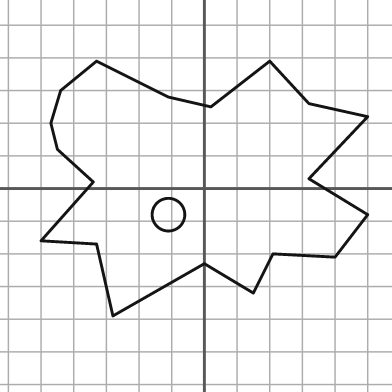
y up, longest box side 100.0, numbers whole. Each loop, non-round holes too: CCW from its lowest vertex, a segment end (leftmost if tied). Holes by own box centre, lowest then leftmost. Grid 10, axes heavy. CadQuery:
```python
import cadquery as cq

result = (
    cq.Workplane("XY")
    .moveTo(-28.0, -39.0)
    .lineTo(0.0, -23.0)
    .lineTo(15.0, -32.0)
    .lineTo(21.0, -20.0)
    .lineTo(40.0, -21.0)
    .lineTo(50.0, -8.0)
    .lineTo(32.0, 3.0)
    .lineTo(50.0, 22.0)
    .lineTo(32.0, 26.0)
    .lineTo(20.0, 39.0)
    .lineTo(2.0, 25.0)
    .lineTo(-11.0, 28.0)
    .lineTo(-33.0, 39.0)
    .lineTo(-44.0, 30.0)
    .lineTo(-47.0, 20.0)
    .lineTo(-45.0, 12.0)
    .lineTo(-34.0, 2.0)
    .lineTo(-50.0, -16.0)
    .lineTo(-33.0, -17.0)
    .close()
    .moveTo(-11.0, -8.0)
    .circle(5.0)
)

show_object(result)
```